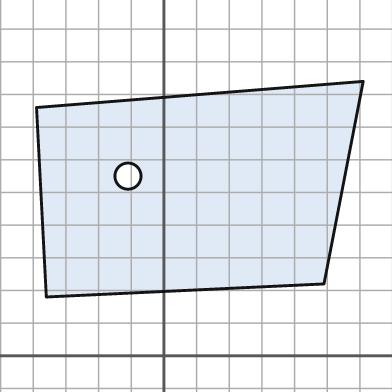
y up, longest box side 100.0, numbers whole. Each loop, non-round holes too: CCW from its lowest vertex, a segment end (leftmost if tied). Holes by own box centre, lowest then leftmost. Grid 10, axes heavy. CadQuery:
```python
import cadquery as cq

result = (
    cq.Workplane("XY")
    .moveTo(-36.0, 18.0)
    .lineTo(49.0, 22.0)
    .lineTo(61.0, 84.0)
    .lineTo(-39.0, 76.0)
    .close()
    .moveTo(-11.0, 55.0)
    .circle(4.0)
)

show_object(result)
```